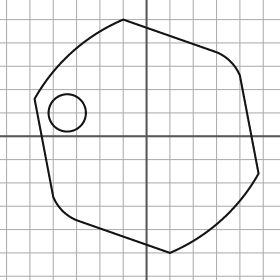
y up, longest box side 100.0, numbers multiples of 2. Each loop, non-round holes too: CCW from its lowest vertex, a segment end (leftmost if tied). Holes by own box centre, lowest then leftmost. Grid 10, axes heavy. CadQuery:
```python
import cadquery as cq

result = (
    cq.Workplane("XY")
    .moveTo(10.0, -50.0)
    .threePointArc((32.0, -36.0), (48.0, -16.0))
    .lineTo(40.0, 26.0)
    .threePointArc((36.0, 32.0), (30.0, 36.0))
    .lineTo(-10.0, 50.0)
    .threePointArc((-32.0, 36.0), (-48.0, 16.0))
    .lineTo(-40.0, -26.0)
    .threePointArc((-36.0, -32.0), (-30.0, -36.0))
    .close()
    .moveTo(-34.0, 10.0)
    .circle(8.0)
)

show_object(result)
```